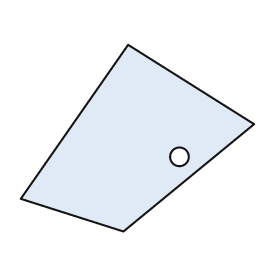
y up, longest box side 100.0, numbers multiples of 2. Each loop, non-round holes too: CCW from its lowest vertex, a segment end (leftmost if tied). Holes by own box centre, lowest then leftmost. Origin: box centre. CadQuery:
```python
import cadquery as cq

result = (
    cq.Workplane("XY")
    .moveTo(-6.0, -40.0)
    .lineTo(50.0, 6.0)
    .lineTo(-4.0, 40.0)
    .lineTo(-50.0, -26.0)
    .close()
    .moveTo(18.0, -8.0)
    .circle(4.0)
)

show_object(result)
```